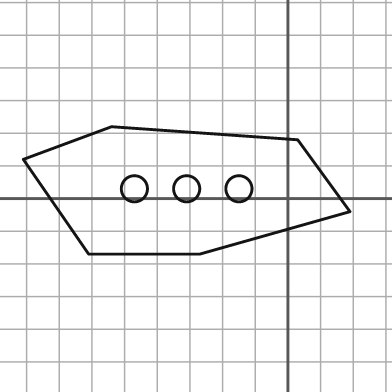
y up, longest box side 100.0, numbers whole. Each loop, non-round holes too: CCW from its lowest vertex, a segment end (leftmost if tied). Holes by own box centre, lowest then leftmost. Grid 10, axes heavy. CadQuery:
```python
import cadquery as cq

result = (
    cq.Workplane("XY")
    .moveTo(-61.0, -17.0)
    .lineTo(-27.0, -17.0)
    .lineTo(19.0, -4.0)
    .lineTo(3.0, 18.0)
    .lineTo(-54.0, 22.0)
    .lineTo(-81.0, 12.0)
    .close()
    .moveTo(-47.0, 3.0)
    .circle(4.0)
    .moveTo(-31.0, 3.0)
    .circle(4.0)
    .moveTo(-15.0, 3.0)
    .circle(4.0)
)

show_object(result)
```